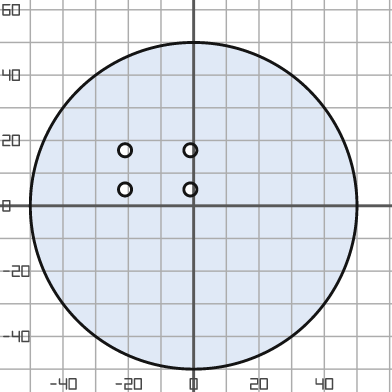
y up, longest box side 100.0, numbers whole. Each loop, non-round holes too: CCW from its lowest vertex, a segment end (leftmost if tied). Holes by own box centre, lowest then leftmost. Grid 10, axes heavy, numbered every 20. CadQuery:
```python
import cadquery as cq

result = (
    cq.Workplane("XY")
    .moveTo(0.0, 0.0)
    .circle(50.0)
    .moveTo(-21.0, 5.0)
    .circle(2.0)
    .moveTo(-1.0, 5.0)
    .circle(2.0)
    .moveTo(-21.0, 17.0)
    .circle(2.0)
    .moveTo(-1.0, 17.0)
    .circle(2.0)
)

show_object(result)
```